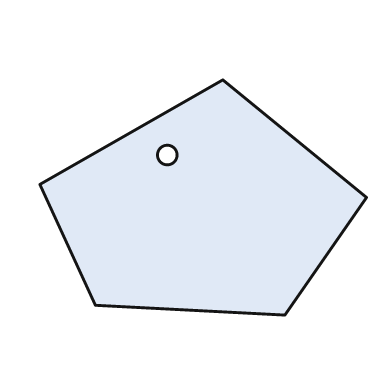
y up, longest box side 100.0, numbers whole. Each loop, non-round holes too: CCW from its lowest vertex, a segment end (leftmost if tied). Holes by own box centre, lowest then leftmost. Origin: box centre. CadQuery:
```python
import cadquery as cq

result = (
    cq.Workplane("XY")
    .moveTo(25.0, -36.0)
    .lineTo(50.0, 0.0)
    .lineTo(6.0, 36.0)
    .lineTo(-50.0, 4.0)
    .lineTo(-33.0, -33.0)
    .close()
    .moveTo(-11.0, 13.0)
    .circle(3.0)
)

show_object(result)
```